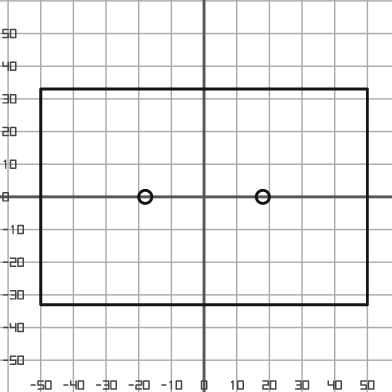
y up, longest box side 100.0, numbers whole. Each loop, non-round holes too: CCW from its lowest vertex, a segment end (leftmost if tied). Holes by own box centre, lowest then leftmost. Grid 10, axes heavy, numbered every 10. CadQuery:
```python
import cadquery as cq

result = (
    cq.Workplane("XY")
    .moveTo(-50.0, -33.0)
    .lineTo(50.0, -33.0)
    .lineTo(50.0, 33.0)
    .lineTo(-50.0, 33.0)
    .close()
    .moveTo(-18.0, 0.0)
    .circle(2.0)
    .moveTo(18.0, 0.0)
    .circle(2.0)
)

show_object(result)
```